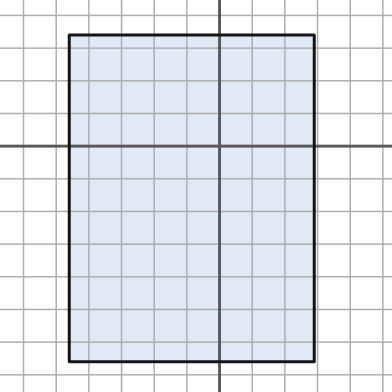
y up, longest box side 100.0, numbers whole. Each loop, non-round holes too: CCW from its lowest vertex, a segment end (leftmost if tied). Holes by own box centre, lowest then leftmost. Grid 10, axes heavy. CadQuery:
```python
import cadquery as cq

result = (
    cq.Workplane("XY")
    .moveTo(-46.0, -66.0)
    .lineTo(29.0, -66.0)
    .lineTo(29.0, 34.0)
    .lineTo(-46.0, 34.0)
    .close()
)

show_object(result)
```